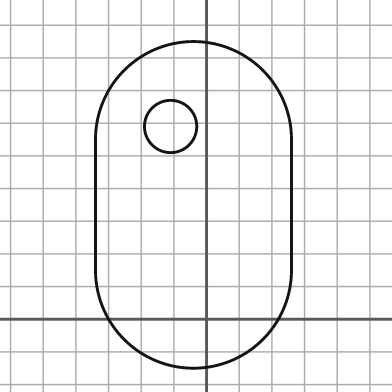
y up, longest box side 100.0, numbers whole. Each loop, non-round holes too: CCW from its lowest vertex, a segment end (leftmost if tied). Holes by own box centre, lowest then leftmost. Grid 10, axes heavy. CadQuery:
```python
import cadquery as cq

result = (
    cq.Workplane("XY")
    .moveTo(-34.0, 15.0)
    .threePointArc((-4.0, -15.0), (26.0, 15.0))
    .lineTo(26.0, 55.0)
    .threePointArc((-4.0, 85.0), (-34.0, 55.0))
    .close()
    .moveTo(-11.0, 59.0)
    .circle(8.0)
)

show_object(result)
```